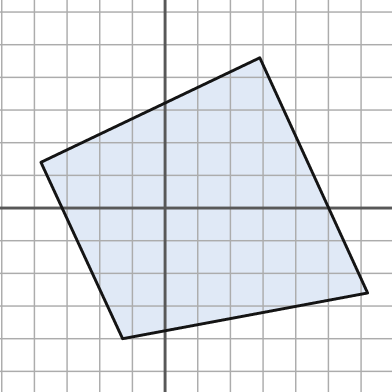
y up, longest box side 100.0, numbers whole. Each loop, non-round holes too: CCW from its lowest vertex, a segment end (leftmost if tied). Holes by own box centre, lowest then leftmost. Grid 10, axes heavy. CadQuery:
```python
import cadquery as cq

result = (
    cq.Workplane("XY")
    .moveTo(-13.0, -40.0)
    .lineTo(62.0, -26.0)
    .lineTo(29.0, 46.0)
    .lineTo(-38.0, 14.0)
    .close()
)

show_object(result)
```